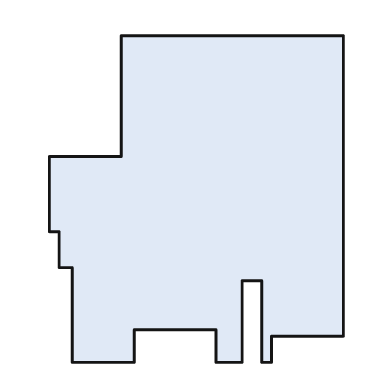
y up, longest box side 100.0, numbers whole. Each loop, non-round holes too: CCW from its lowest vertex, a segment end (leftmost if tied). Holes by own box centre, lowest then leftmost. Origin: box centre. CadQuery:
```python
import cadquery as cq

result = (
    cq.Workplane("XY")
    .moveTo(-38.0, -50.0)
    .lineTo(-19.0, -50.0)
    .lineTo(-19.0, -40.0)
    .lineTo(6.0, -40.0)
    .lineTo(6.0, -50.0)
    .lineTo(14.0, -50.0)
    .lineTo(14.0, -25.0)
    .lineTo(20.0, -25.0)
    .lineTo(20.0, -50.0)
    .lineTo(23.0, -50.0)
    .lineTo(23.0, -42.0)
    .lineTo(45.0, -42.0)
    .lineTo(45.0, 50.0)
    .lineTo(-23.0, 50.0)
    .lineTo(-23.0, 13.0)
    .lineTo(-45.0, 13.0)
    .lineTo(-45.0, -10.0)
    .lineTo(-42.0, -10.0)
    .lineTo(-42.0, -21.0)
    .lineTo(-38.0, -21.0)
    .close()
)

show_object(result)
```